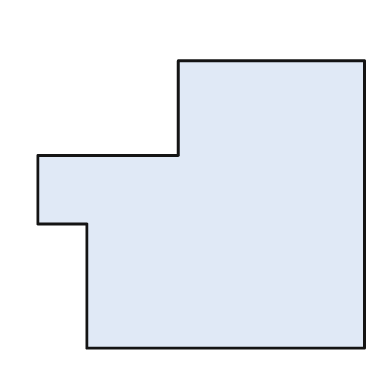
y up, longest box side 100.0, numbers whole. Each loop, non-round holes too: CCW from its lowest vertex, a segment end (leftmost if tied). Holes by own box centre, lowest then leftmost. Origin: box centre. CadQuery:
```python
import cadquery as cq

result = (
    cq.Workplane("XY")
    .moveTo(-35.0, -44.0)
    .lineTo(50.0, -44.0)
    .lineTo(50.0, 44.0)
    .lineTo(-7.0, 44.0)
    .lineTo(-7.0, 15.0)
    .lineTo(-50.0, 15.0)
    .lineTo(-50.0, -6.0)
    .lineTo(-35.0, -6.0)
    .close()
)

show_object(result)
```